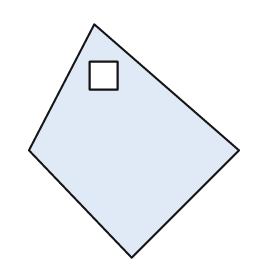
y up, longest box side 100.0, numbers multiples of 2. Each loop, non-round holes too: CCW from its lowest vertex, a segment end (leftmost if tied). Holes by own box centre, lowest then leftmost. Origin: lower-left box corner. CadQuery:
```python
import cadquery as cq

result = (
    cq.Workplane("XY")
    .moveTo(44.0, 0.0)
    .lineTo(90.0, 46.0)
    .lineTo(28.0, 100.0)
    .lineTo(0.0, 46.0)
    .close()
    .moveTo(26.0, 72.0)
    .lineTo(38.0, 72.0)
    .lineTo(38.0, 84.0)
    .lineTo(26.0, 84.0)
    .close()
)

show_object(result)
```